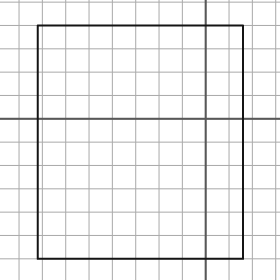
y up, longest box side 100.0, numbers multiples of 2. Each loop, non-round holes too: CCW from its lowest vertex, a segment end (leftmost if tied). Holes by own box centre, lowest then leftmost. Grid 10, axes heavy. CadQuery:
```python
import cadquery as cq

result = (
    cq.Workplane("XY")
    .moveTo(-72.0, -60.0)
    .lineTo(16.0, -60.0)
    .lineTo(16.0, 40.0)
    .lineTo(-72.0, 40.0)
    .close()
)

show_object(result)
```